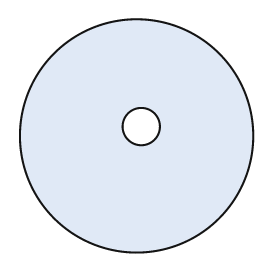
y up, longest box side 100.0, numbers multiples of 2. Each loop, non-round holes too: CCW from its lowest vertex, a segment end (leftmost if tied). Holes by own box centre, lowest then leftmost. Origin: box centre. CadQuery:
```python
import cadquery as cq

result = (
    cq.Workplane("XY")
    .moveTo(0.0, 0.0)
    .circle(50.0)
    .moveTo(2.0, 4.0)
    .circle(8.0)
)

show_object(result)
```